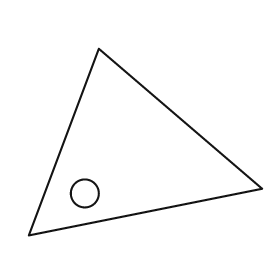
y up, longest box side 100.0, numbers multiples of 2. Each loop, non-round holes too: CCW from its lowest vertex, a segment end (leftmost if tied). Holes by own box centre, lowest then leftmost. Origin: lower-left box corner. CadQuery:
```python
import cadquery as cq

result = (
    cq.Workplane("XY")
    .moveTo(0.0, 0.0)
    .lineTo(100.0, 20.0)
    .lineTo(30.0, 80.0)
    .close()
    .moveTo(24.0, 18.0)
    .circle(6.0)
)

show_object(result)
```